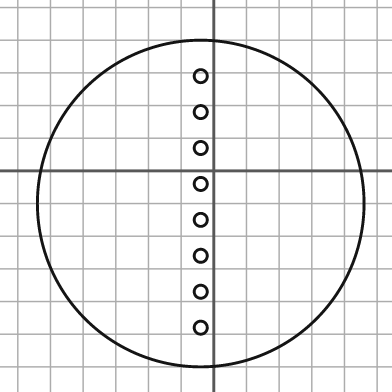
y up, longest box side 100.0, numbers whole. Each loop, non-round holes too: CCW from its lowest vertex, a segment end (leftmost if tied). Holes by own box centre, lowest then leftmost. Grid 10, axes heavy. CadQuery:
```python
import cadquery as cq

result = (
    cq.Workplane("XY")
    .moveTo(-4.0, -10.0)
    .circle(50.0)
    .moveTo(-4.0, -48.0)
    .circle(2.0)
    .moveTo(-4.0, -37.0)
    .circle(2.0)
    .moveTo(-4.0, -26.0)
    .circle(2.0)
    .moveTo(-4.0, -15.0)
    .circle(2.0)
    .moveTo(-4.0, -4.0)
    .circle(2.0)
    .moveTo(-4.0, 7.0)
    .circle(2.0)
    .moveTo(-4.0, 18.0)
    .circle(2.0)
    .moveTo(-4.0, 29.0)
    .circle(2.0)
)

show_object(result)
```